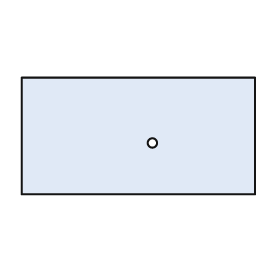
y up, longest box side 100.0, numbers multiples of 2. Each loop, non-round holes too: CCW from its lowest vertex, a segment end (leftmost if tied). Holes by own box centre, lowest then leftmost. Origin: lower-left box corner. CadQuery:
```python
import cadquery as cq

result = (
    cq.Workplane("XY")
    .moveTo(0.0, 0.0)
    .lineTo(100.0, 0.0)
    .lineTo(100.0, 50.0)
    .lineTo(0.0, 50.0)
    .close()
    .moveTo(56.0, 22.0)
    .circle(2.0)
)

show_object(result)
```